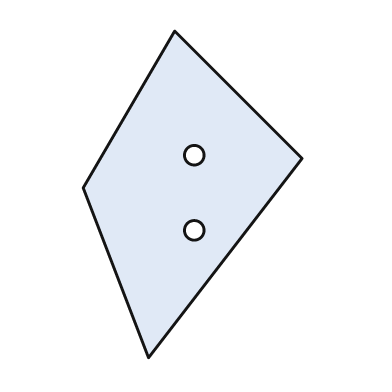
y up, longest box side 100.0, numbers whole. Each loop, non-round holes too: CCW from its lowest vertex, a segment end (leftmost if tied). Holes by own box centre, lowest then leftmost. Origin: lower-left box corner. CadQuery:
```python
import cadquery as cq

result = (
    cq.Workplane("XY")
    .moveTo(20.0, 0.0)
    .lineTo(67.0, 61.0)
    .lineTo(28.0, 100.0)
    .lineTo(0.0, 52.0)
    .close()
    .moveTo(34.0, 39.0)
    .circle(3.0)
    .moveTo(34.0, 62.0)
    .circle(3.0)
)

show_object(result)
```